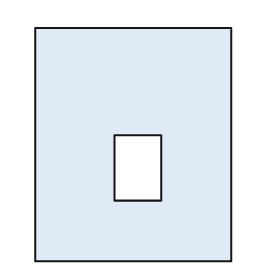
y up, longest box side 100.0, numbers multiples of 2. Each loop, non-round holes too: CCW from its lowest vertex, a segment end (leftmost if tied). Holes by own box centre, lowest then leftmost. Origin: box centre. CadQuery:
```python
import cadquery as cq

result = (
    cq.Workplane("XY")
    .moveTo(-42.0, -50.0)
    .lineTo(42.0, -50.0)
    .lineTo(42.0, 50.0)
    .lineTo(-42.0, 50.0)
    .close()
    .moveTo(-8.0, -24.0)
    .lineTo(12.0, -24.0)
    .lineTo(12.0, 4.0)
    .lineTo(-8.0, 4.0)
    .close()
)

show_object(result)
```